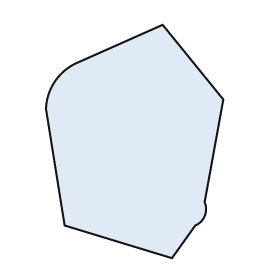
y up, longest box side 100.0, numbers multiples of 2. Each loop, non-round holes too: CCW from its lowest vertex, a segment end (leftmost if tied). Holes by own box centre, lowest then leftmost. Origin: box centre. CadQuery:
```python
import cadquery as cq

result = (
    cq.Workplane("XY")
    .moveTo(16.0, -50.0)
    .lineTo(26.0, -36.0)
    .threePointArc((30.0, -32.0), (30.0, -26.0))
    .lineTo(38.0, 18.0)
    .lineTo(12.0, 50.0)
    .lineTo(-24.0, 34.0)
    .threePointArc((-34.0, 26.0), (-38.0, 14.0))
    .lineTo(-30.0, -36.0)
    .close()
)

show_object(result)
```